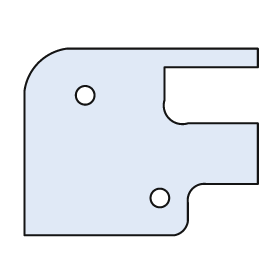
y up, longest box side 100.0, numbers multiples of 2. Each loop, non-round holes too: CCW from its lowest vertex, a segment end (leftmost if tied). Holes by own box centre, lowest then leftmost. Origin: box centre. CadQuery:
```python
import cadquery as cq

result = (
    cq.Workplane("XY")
    .moveTo(-50.0, -40.0)
    .lineTo(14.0, -40.0)
    .threePointArc((18.0, -38.0), (20.0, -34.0))
    .lineTo(20.0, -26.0)
    .threePointArc((22.0, -20.0), (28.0, -18.0))
    .lineTo(50.0, -18.0)
    .lineTo(50.0, 8.0)
    .lineTo(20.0, 8.0)
    .threePointArc((12.0, 10.0), (10.0, 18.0))
    .lineTo(10.0, 32.0)
    .lineTo(50.0, 32.0)
    .lineTo(50.0, 40.0)
    .lineTo(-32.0, 40.0)
    .threePointArc((-44.0, 34.0), (-50.0, 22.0))
    .close()
    .moveTo(8.0, -24.0)
    .circle(4.0)
    .moveTo(-24.0, 20.0)
    .circle(4.0)
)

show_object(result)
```